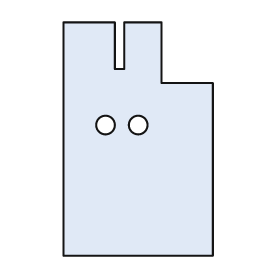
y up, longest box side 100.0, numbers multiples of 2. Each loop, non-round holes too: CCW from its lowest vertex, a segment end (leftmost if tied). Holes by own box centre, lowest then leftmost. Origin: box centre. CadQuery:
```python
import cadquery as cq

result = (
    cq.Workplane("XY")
    .moveTo(-32.0, -50.0)
    .lineTo(32.0, -50.0)
    .lineTo(32.0, 24.0)
    .lineTo(10.0, 24.0)
    .lineTo(10.0, 50.0)
    .lineTo(-6.0, 50.0)
    .lineTo(-6.0, 30.0)
    .lineTo(-10.0, 30.0)
    .lineTo(-10.0, 50.0)
    .lineTo(-32.0, 50.0)
    .close()
    .moveTo(-14.0, 6.0)
    .circle(4.0)
    .moveTo(0.0, 6.0)
    .circle(4.0)
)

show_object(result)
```